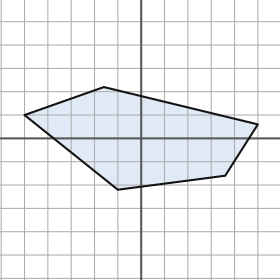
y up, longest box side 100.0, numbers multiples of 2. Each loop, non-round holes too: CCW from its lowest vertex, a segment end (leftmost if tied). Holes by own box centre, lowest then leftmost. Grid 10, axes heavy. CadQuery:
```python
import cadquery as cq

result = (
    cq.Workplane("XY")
    .moveTo(-10.0, -22.0)
    .lineTo(36.0, -16.0)
    .lineTo(50.0, 6.0)
    .lineTo(-16.0, 22.0)
    .lineTo(-50.0, 10.0)
    .close()
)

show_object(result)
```